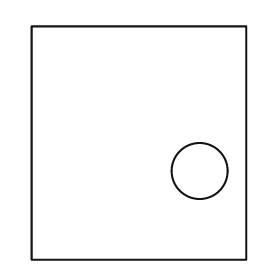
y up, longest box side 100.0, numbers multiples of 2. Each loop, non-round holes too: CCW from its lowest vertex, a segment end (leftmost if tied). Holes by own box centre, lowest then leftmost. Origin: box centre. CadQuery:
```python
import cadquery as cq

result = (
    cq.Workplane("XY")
    .moveTo(-46.0, -50.0)
    .lineTo(46.0, -50.0)
    .lineTo(46.0, 50.0)
    .lineTo(-46.0, 50.0)
    .close()
    .moveTo(26.0, -12.0)
    .circle(12.0)
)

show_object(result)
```